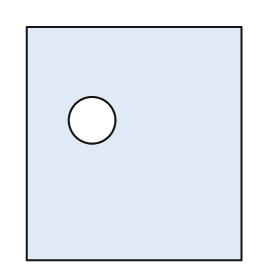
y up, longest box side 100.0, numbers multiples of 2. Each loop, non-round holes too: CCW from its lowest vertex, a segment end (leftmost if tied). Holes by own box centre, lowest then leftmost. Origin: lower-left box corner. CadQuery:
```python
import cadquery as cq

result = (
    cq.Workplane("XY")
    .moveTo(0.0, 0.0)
    .lineTo(92.0, 0.0)
    .lineTo(92.0, 100.0)
    .lineTo(0.0, 100.0)
    .close()
    .moveTo(28.0, 60.0)
    .circle(10.0)
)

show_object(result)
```